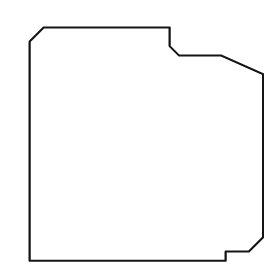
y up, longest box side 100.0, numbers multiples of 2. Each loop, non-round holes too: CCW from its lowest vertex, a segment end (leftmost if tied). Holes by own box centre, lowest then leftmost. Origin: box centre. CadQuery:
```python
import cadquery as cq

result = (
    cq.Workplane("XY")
    .moveTo(-50.0, -50.0)
    .lineTo(34.0, -50.0)
    .lineTo(34.0, -46.0)
    .lineTo(44.0, -46.0)
    .lineTo(50.0, -40.0)
    .lineTo(50.0, 30.0)
    .lineTo(32.0, 38.0)
    .lineTo(14.0, 38.0)
    .lineTo(10.0, 42.0)
    .lineTo(10.0, 50.0)
    .lineTo(-44.0, 50.0)
    .lineTo(-50.0, 44.0)
    .close()
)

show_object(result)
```